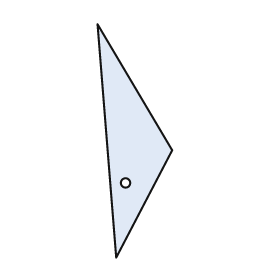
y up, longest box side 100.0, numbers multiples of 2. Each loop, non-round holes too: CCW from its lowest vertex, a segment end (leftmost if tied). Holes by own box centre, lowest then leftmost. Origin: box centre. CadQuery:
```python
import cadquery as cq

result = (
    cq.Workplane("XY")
    .moveTo(-8.0, -50.0)
    .lineTo(16.0, -4.0)
    .lineTo(-16.0, 50.0)
    .close()
    .moveTo(-4.0, -18.0)
    .circle(2.0)
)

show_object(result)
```